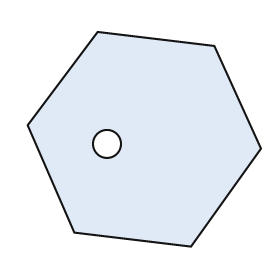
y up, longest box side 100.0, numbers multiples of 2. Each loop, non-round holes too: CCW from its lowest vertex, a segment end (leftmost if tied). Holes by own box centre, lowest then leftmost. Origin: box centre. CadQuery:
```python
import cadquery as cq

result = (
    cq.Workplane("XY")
    .moveTo(20.0, -46.0)
    .lineTo(50.0, -4.0)
    .lineTo(30.0, 40.0)
    .lineTo(-20.0, 46.0)
    .lineTo(-50.0, 6.0)
    .lineTo(-30.0, -40.0)
    .close()
    .moveTo(-16.0, -2.0)
    .circle(6.0)
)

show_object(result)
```